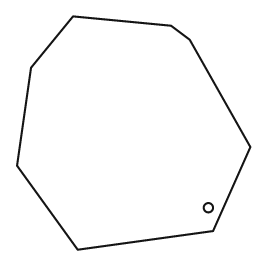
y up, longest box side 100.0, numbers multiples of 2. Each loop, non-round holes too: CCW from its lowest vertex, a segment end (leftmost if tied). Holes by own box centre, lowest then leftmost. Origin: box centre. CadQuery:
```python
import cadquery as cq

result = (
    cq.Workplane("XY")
    .moveTo(-24.0, -50.0)
    .lineTo(34.0, -42.0)
    .lineTo(50.0, -6.0)
    .lineTo(24.0, 40.0)
    .lineTo(16.0, 46.0)
    .lineTo(-26.0, 50.0)
    .lineTo(-44.0, 28.0)
    .lineTo(-50.0, -14.0)
    .close()
    .moveTo(32.0, -32.0)
    .circle(2.0)
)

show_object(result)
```